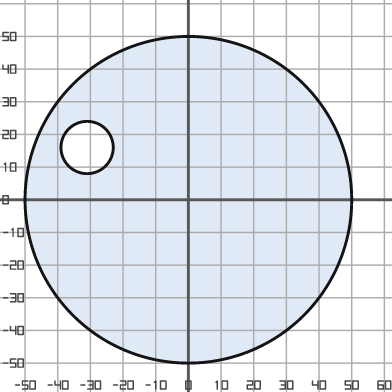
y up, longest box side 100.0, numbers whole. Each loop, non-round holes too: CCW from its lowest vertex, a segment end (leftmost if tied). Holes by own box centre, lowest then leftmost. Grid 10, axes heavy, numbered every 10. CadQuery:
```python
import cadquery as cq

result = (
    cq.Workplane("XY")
    .moveTo(0.0, 0.0)
    .circle(50.0)
    .moveTo(-31.0, 16.0)
    .circle(8.0)
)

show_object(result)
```